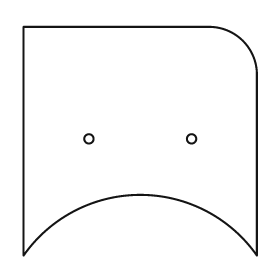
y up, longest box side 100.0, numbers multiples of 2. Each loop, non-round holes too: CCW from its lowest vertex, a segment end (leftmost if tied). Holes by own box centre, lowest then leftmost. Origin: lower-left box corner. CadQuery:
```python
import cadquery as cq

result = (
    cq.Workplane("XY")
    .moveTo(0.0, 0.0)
    .threePointArc((50.0, 26.0), (100.0, 0.0))
    .lineTo(100.0, 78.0)
    .threePointArc((94.0, 92.0), (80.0, 98.0))
    .lineTo(0.0, 98.0)
    .close()
    .moveTo(28.0, 50.0)
    .circle(2.0)
    .moveTo(72.0, 50.0)
    .circle(2.0)
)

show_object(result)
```